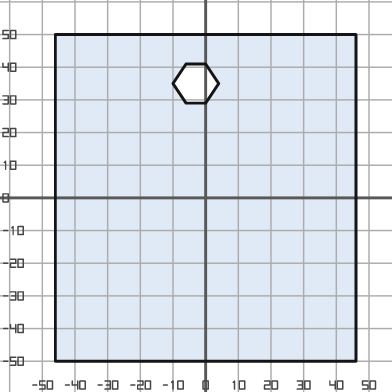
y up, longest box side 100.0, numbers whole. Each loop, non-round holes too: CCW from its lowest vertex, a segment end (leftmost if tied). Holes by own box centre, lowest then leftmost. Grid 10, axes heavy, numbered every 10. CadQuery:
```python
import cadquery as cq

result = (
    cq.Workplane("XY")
    .moveTo(-46.0, -50.0)
    .lineTo(46.0, -50.0)
    .lineTo(46.0, 50.0)
    .lineTo(-46.0, 50.0)
    .close()
    .moveTo(-6.0, 29.0)
    .lineTo(0.0, 29.0)
    .lineTo(4.0, 35.0)
    .lineTo(0.0, 41.0)
    .lineTo(-6.0, 41.0)
    .lineTo(-10.0, 35.0)
    .close()
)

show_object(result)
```